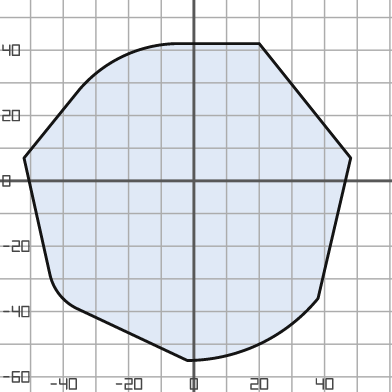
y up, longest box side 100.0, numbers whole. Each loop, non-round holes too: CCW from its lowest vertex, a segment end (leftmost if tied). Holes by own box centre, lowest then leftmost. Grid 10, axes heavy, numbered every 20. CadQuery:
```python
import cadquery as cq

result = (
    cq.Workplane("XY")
    .moveTo(-2.0, -55.0)
    .threePointArc((20.0, -50.0), (38.0, -36.0))
    .lineTo(48.0, 7.0)
    .lineTo(20.0, 42.0)
    .lineTo(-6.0, 42.0)
    .threePointArc((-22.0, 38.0), (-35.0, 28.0))
    .lineTo(-52.0, 7.0)
    .lineTo(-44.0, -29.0)
    .threePointArc((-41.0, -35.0), (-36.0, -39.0))
    .close()
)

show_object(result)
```